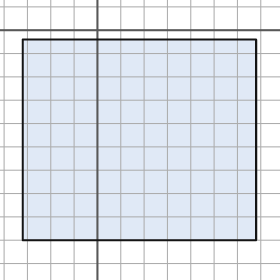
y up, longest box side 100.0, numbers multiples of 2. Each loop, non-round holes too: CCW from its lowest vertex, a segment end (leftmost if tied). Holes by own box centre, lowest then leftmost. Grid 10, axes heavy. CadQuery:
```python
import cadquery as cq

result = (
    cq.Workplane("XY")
    .moveTo(-32.0, -90.0)
    .lineTo(68.0, -90.0)
    .lineTo(68.0, -4.0)
    .lineTo(-32.0, -4.0)
    .close()
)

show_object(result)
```